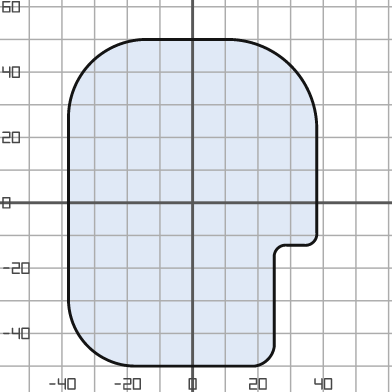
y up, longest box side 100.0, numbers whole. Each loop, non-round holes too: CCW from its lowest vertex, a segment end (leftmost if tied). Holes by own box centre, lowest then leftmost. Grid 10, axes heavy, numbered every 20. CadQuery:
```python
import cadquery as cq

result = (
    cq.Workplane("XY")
    .moveTo(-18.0, -50.0)
    .lineTo(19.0, -50.0)
    .threePointArc((23.0, -48.0), (25.0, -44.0))
    .lineTo(25.0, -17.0)
    .threePointArc((26.0, -14.0), (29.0, -13.0))
    .lineTo(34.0, -13.0)
    .threePointArc((37.0, -12.0), (38.0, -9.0))
    .lineTo(38.0, 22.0)
    .threePointArc((30.0, 42.0), (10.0, 50.0))
    .lineTo(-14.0, 50.0)
    .threePointArc((-31.0, 43.0), (-38.0, 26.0))
    .lineTo(-38.0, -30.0)
    .threePointArc((-32.0, -44.0), (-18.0, -50.0))
    .close()
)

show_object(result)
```